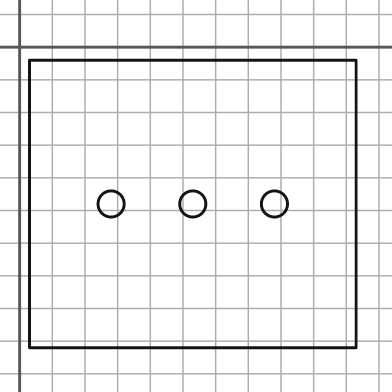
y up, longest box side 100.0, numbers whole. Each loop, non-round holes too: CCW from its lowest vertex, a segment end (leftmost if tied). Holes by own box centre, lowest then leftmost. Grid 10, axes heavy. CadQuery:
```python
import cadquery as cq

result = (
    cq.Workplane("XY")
    .moveTo(3.0, -92.0)
    .lineTo(103.0, -92.0)
    .lineTo(103.0, -4.0)
    .lineTo(3.0, -4.0)
    .close()
    .moveTo(28.0, -48.0)
    .circle(4.0)
    .moveTo(53.0, -48.0)
    .circle(4.0)
    .moveTo(78.0, -48.0)
    .circle(4.0)
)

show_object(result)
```